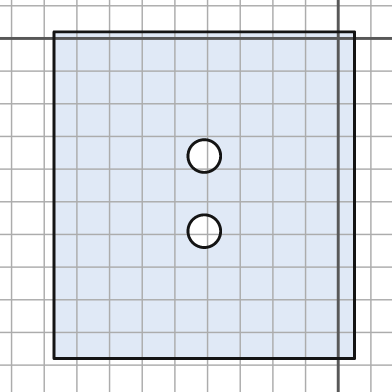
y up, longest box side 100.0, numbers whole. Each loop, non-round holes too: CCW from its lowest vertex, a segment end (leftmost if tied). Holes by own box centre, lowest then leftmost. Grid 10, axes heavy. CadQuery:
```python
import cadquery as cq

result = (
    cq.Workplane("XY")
    .moveTo(-87.0, -98.0)
    .lineTo(5.0, -98.0)
    .lineTo(5.0, 2.0)
    .lineTo(-87.0, 2.0)
    .close()
    .moveTo(-41.0, -59.0)
    .circle(5.0)
    .moveTo(-41.0, -36.0)
    .circle(5.0)
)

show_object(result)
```